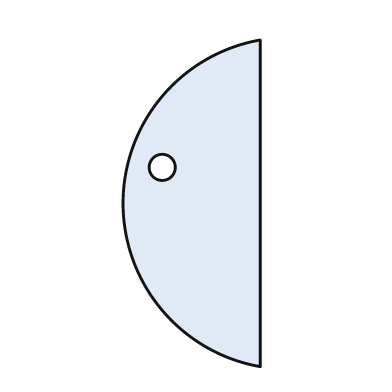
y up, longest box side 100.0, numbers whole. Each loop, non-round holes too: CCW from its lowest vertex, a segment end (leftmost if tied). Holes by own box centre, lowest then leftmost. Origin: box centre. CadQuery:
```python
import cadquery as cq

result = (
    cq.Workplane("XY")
    .moveTo(21.0, -50.0)
    .lineTo(21.0, 50.0)
    .threePointArc((-21.0, 0.0), (21.0, -50.0))
    .close()
    .moveTo(-9.0, 11.0)
    .circle(4.0)
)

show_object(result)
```